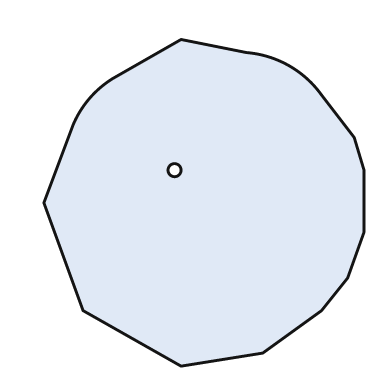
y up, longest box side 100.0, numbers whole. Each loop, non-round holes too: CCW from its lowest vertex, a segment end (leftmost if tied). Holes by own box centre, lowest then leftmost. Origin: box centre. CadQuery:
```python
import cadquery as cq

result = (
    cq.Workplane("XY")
    .moveTo(-7.0, -50.0)
    .lineTo(18.0, -46.0)
    .lineTo(36.0, -33.0)
    .lineTo(44.0, -23.0)
    .lineTo(49.0, -9.0)
    .lineTo(49.0, 10.0)
    .lineTo(46.0, 20.0)
    .lineTo(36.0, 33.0)
    .threePointArc((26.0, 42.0), (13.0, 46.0))
    .lineTo(-7.0, 50.0)
    .lineTo(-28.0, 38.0)
    .threePointArc((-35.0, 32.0), (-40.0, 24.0))
    .lineTo(-49.0, 0.0)
    .lineTo(-37.0, -33.0)
    .close()
    .moveTo(-9.0, 10.0)
    .circle(2.0)
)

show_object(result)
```